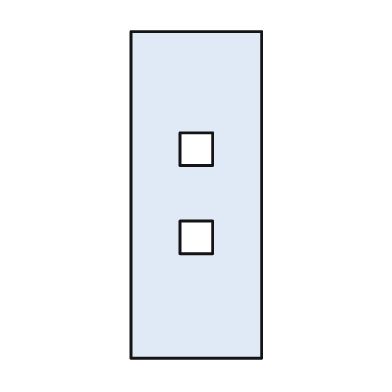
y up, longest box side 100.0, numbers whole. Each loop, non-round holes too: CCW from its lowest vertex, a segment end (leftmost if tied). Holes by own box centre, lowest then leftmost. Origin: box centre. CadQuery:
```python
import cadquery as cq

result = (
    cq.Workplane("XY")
    .moveTo(-20.0, -50.0)
    .lineTo(20.0, -50.0)
    .lineTo(20.0, 50.0)
    .lineTo(-20.0, 50.0)
    .close()
    .moveTo(-5.0, -18.0)
    .lineTo(5.0, -18.0)
    .lineTo(5.0, -8.0)
    .lineTo(-5.0, -8.0)
    .close()
    .moveTo(-5.0, 9.0)
    .lineTo(5.0, 9.0)
    .lineTo(5.0, 19.0)
    .lineTo(-5.0, 19.0)
    .close()
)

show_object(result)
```